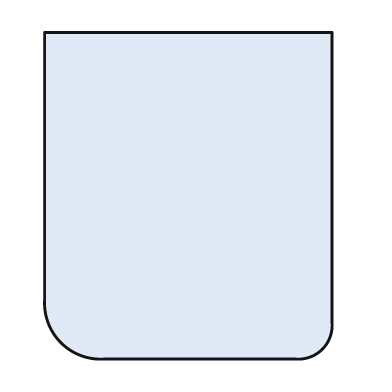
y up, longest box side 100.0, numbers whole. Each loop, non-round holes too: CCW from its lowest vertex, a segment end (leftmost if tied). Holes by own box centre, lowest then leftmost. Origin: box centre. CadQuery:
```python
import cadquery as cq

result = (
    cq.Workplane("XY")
    .moveTo(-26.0, -50.0)
    .lineTo(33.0, -50.0)
    .threePointArc((41.0, -47.0), (44.0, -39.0))
    .lineTo(44.0, 50.0)
    .lineTo(-44.0, 50.0)
    .lineTo(-44.0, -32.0)
    .threePointArc((-39.0, -45.0), (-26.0, -50.0))
    .close()
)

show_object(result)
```